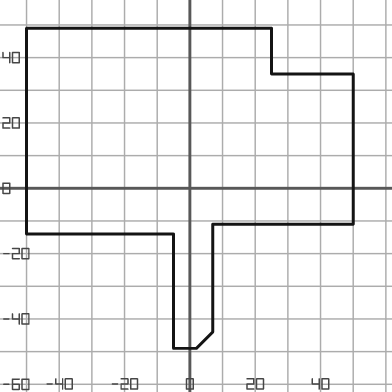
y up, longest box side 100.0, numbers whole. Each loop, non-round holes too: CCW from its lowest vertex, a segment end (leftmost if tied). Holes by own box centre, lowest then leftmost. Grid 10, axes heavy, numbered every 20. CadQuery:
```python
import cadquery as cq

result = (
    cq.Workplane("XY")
    .moveTo(-5.0, -49.0)
    .lineTo(2.0, -49.0)
    .lineTo(7.0, -44.0)
    .lineTo(7.0, -11.0)
    .lineTo(50.0, -11.0)
    .lineTo(50.0, 35.0)
    .lineTo(25.0, 35.0)
    .lineTo(25.0, 49.0)
    .lineTo(-50.0, 49.0)
    .lineTo(-50.0, -14.0)
    .lineTo(-5.0, -14.0)
    .close()
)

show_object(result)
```